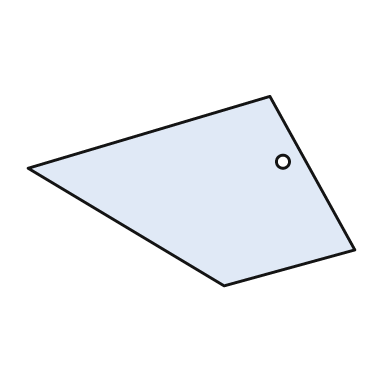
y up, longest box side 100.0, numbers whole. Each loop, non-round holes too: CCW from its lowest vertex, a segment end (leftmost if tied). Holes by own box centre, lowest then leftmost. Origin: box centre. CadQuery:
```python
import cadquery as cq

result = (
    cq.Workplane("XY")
    .moveTo(10.0, -29.0)
    .lineTo(50.0, -18.0)
    .lineTo(24.0, 29.0)
    .lineTo(-50.0, 7.0)
    .close()
    .moveTo(28.0, 9.0)
    .circle(2.0)
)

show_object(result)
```